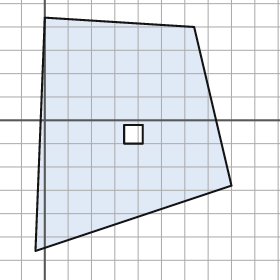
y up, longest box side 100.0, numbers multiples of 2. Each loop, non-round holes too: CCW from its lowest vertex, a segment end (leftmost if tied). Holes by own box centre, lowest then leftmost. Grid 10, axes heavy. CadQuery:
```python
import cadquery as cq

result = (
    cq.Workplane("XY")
    .moveTo(-4.0, -56.0)
    .lineTo(80.0, -28.0)
    .lineTo(64.0, 40.0)
    .lineTo(0.0, 44.0)
    .close()
    .moveTo(34.0, -10.0)
    .lineTo(42.0, -10.0)
    .lineTo(42.0, -2.0)
    .lineTo(34.0, -2.0)
    .close()
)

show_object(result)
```